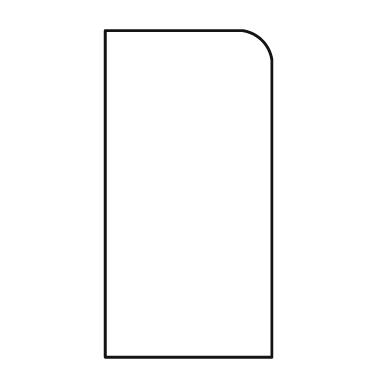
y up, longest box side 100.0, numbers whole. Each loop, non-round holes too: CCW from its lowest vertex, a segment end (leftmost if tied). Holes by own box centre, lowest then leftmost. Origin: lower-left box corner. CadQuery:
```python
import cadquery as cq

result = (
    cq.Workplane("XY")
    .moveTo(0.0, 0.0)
    .lineTo(51.0, 0.0)
    .lineTo(51.0, 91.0)
    .threePointArc((48.0, 97.0), (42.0, 100.0))
    .lineTo(0.0, 100.0)
    .close()
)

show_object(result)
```